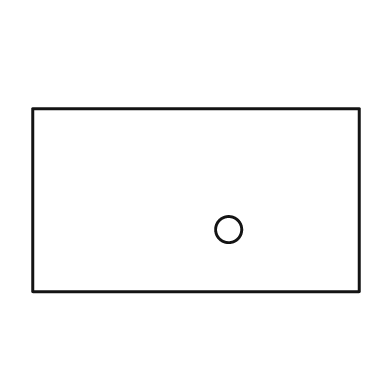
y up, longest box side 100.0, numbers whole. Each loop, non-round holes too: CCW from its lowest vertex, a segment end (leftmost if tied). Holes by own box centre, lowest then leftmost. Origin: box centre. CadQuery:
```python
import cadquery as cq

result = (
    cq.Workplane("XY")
    .moveTo(-50.0, -28.0)
    .lineTo(50.0, -28.0)
    .lineTo(50.0, 28.0)
    .lineTo(-50.0, 28.0)
    .close()
    .moveTo(10.0, -9.0)
    .circle(4.0)
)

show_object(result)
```